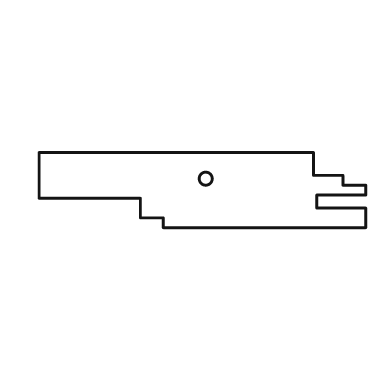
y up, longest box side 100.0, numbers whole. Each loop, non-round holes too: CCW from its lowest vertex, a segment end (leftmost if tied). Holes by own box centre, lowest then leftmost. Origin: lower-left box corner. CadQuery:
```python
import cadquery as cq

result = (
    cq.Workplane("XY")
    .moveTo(38.0, 0.0)
    .lineTo(100.0, 0.0)
    .lineTo(100.0, 6.0)
    .lineTo(85.0, 6.0)
    .lineTo(85.0, 10.0)
    .lineTo(100.0, 10.0)
    .lineTo(100.0, 13.0)
    .lineTo(93.0, 13.0)
    .lineTo(93.0, 16.0)
    .lineTo(84.0, 16.0)
    .lineTo(84.0, 23.0)
    .lineTo(0.0, 23.0)
    .lineTo(0.0, 9.0)
    .lineTo(31.0, 9.0)
    .lineTo(31.0, 3.0)
    .lineTo(38.0, 3.0)
    .close()
    .moveTo(51.0, 15.0)
    .circle(2.0)
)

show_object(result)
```